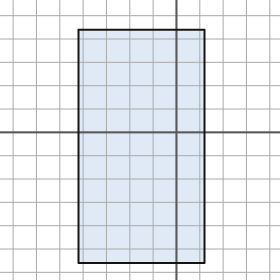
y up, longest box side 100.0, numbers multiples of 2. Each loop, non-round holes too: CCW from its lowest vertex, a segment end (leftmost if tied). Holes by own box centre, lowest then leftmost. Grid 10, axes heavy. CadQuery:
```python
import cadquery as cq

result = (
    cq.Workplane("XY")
    .moveTo(-42.0, -56.0)
    .lineTo(12.0, -56.0)
    .lineTo(12.0, 44.0)
    .lineTo(-42.0, 44.0)
    .close()
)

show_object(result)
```